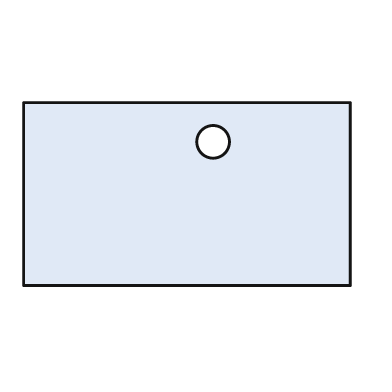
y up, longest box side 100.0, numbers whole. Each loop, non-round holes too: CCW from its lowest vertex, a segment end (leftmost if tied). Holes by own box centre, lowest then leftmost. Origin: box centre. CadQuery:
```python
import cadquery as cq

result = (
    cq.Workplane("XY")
    .moveTo(-50.0, -28.0)
    .lineTo(50.0, -28.0)
    .lineTo(50.0, 28.0)
    .lineTo(-50.0, 28.0)
    .close()
    .moveTo(8.0, 16.0)
    .circle(5.0)
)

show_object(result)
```